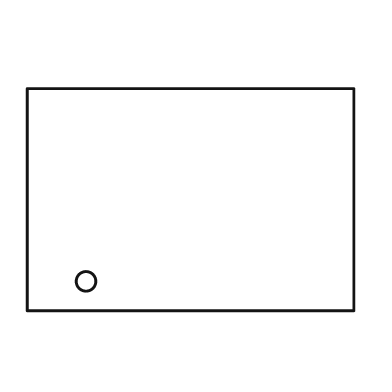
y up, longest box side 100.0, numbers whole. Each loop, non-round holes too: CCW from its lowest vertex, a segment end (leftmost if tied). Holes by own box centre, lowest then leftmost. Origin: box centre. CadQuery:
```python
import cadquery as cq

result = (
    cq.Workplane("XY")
    .moveTo(-50.0, -34.0)
    .lineTo(50.0, -34.0)
    .lineTo(50.0, 34.0)
    .lineTo(-50.0, 34.0)
    .close()
    .moveTo(-32.0, -25.0)
    .circle(3.0)
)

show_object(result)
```